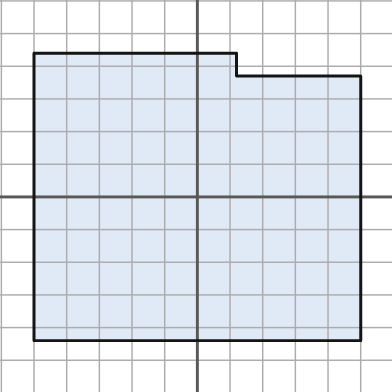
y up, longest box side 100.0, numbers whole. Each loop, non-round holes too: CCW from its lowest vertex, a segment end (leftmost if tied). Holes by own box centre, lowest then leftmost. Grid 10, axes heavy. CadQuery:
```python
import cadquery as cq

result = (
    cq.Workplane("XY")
    .moveTo(-50.0, -44.0)
    .lineTo(50.0, -44.0)
    .lineTo(50.0, 37.0)
    .lineTo(12.0, 37.0)
    .lineTo(12.0, 44.0)
    .lineTo(-50.0, 44.0)
    .close()
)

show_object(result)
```